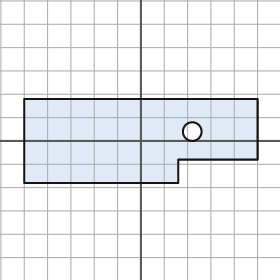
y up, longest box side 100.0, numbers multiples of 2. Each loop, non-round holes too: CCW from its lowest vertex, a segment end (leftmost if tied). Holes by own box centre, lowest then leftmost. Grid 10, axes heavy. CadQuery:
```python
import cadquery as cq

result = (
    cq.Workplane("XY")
    .moveTo(-50.0, -18.0)
    .lineTo(16.0, -18.0)
    .lineTo(16.0, -8.0)
    .lineTo(50.0, -8.0)
    .lineTo(50.0, 18.0)
    .lineTo(-50.0, 18.0)
    .close()
    .moveTo(22.0, 4.0)
    .circle(4.0)
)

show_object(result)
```